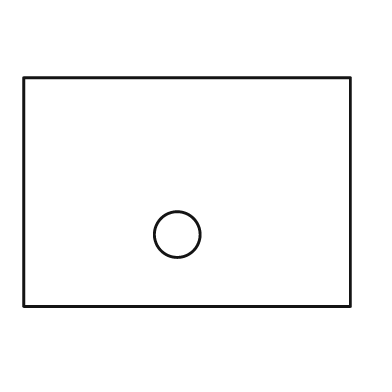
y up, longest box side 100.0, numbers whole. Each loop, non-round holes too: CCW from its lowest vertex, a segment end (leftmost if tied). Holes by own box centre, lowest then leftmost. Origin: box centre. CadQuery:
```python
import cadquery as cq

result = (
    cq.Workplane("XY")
    .moveTo(-50.0, -35.0)
    .lineTo(50.0, -35.0)
    .lineTo(50.0, 35.0)
    .lineTo(-50.0, 35.0)
    .close()
    .moveTo(-3.0, -13.0)
    .circle(7.0)
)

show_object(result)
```